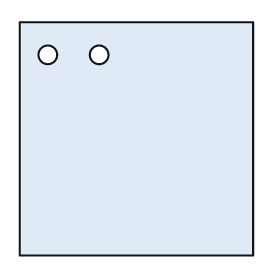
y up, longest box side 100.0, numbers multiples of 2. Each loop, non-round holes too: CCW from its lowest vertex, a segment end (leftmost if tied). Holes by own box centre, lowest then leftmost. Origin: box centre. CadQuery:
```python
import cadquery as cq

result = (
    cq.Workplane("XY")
    .moveTo(-50.0, -50.0)
    .lineTo(50.0, -50.0)
    .lineTo(50.0, 50.0)
    .lineTo(-50.0, 50.0)
    .close()
    .moveTo(-38.0, 36.0)
    .circle(4.0)
    .moveTo(-16.0, 36.0)
    .circle(4.0)
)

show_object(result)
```